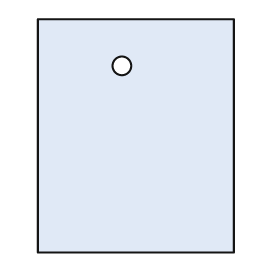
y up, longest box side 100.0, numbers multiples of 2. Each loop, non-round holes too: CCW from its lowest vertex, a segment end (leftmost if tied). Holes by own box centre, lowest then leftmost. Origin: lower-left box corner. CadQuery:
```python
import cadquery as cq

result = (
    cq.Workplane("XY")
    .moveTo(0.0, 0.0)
    .lineTo(84.0, 0.0)
    .lineTo(84.0, 100.0)
    .lineTo(0.0, 100.0)
    .close()
    .moveTo(36.0, 80.0)
    .circle(4.0)
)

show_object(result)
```